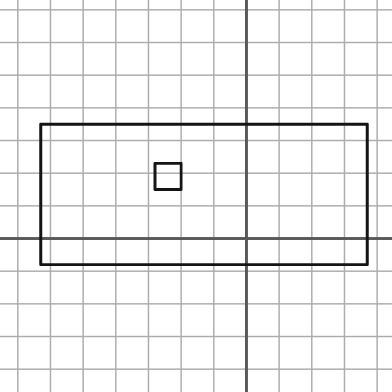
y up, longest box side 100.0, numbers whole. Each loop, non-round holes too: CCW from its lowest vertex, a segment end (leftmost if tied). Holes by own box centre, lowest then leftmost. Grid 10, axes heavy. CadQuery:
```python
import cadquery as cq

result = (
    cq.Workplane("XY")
    .moveTo(-63.0, -8.0)
    .lineTo(37.0, -8.0)
    .lineTo(37.0, 35.0)
    .lineTo(-63.0, 35.0)
    .close()
    .moveTo(-28.0, 15.0)
    .lineTo(-20.0, 15.0)
    .lineTo(-20.0, 23.0)
    .lineTo(-28.0, 23.0)
    .close()
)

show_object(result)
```